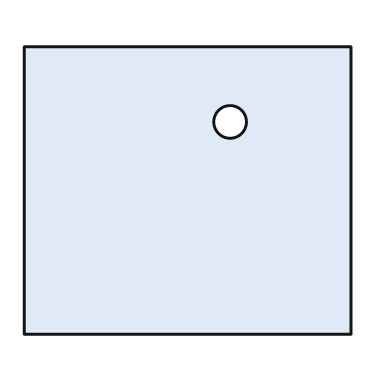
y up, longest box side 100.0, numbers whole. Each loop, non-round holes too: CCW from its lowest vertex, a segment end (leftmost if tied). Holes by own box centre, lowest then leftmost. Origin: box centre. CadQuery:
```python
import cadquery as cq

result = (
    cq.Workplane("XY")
    .moveTo(-50.0, -44.0)
    .lineTo(50.0, -44.0)
    .lineTo(50.0, 44.0)
    .lineTo(-50.0, 44.0)
    .close()
    .moveTo(13.0, 21.0)
    .circle(5.0)
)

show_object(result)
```